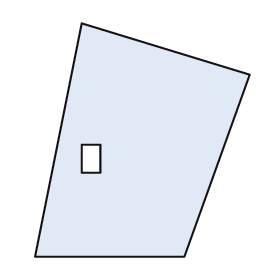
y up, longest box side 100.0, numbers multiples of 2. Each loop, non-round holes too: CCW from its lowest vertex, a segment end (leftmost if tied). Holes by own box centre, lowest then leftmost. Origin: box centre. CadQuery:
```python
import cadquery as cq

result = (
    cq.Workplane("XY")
    .moveTo(-46.0, -50.0)
    .lineTo(18.0, -50.0)
    .lineTo(46.0, 28.0)
    .lineTo(-26.0, 50.0)
    .close()
    .moveTo(-26.0, -14.0)
    .lineTo(-18.0, -14.0)
    .lineTo(-18.0, -2.0)
    .lineTo(-26.0, -2.0)
    .close()
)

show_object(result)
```